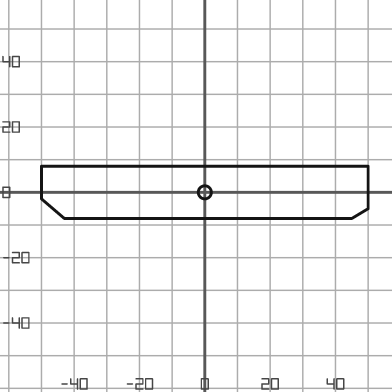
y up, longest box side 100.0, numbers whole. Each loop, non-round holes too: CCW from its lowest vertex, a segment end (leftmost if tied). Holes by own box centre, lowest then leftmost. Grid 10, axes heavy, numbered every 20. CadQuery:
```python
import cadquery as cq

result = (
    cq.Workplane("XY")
    .moveTo(-43.0, -8.0)
    .lineTo(45.0, -8.0)
    .lineTo(50.0, -5.0)
    .lineTo(50.0, 8.0)
    .lineTo(-50.0, 8.0)
    .lineTo(-50.0, -2.0)
    .close()
    .moveTo(0.0, 0.0)
    .circle(2.0)
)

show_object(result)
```